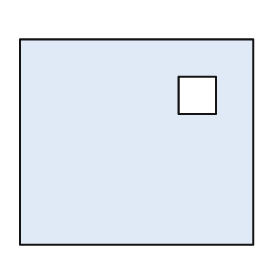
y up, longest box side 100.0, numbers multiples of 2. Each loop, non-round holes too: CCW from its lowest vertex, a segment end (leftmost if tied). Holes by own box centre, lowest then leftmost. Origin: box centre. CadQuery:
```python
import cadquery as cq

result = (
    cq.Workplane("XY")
    .moveTo(-50.0, -44.0)
    .lineTo(50.0, -44.0)
    .lineTo(50.0, 44.0)
    .lineTo(-50.0, 44.0)
    .close()
    .moveTo(18.0, 12.0)
    .lineTo(34.0, 12.0)
    .lineTo(34.0, 28.0)
    .lineTo(18.0, 28.0)
    .close()
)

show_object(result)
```